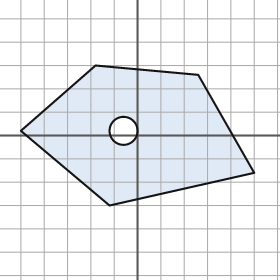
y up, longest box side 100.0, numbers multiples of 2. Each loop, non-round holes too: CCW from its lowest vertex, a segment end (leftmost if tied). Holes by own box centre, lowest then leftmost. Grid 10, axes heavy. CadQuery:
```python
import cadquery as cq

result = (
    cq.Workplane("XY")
    .moveTo(-12.0, -30.0)
    .lineTo(50.0, -16.0)
    .lineTo(26.0, 26.0)
    .lineTo(-18.0, 30.0)
    .lineTo(-50.0, 2.0)
    .close()
    .moveTo(-6.0, 2.0)
    .circle(6.0)
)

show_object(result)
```